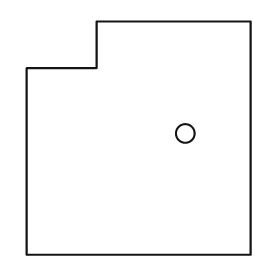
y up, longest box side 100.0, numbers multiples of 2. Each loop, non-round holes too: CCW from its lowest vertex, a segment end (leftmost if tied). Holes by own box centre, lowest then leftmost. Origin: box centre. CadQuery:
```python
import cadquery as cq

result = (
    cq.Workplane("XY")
    .moveTo(-48.0, -50.0)
    .lineTo(48.0, -50.0)
    .lineTo(48.0, 50.0)
    .lineTo(-18.0, 50.0)
    .lineTo(-18.0, 30.0)
    .lineTo(-48.0, 30.0)
    .close()
    .moveTo(20.0, 2.0)
    .circle(4.0)
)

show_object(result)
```